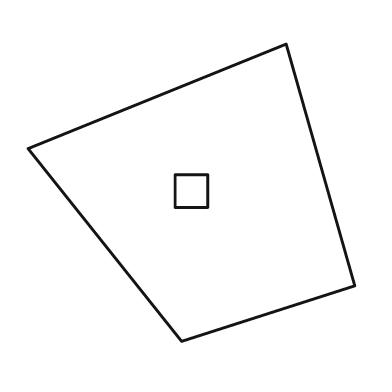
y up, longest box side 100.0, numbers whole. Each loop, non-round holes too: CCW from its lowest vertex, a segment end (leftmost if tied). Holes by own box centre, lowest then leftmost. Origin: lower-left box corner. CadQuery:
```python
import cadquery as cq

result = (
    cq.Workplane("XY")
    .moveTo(47.0, 0.0)
    .lineTo(100.0, 17.0)
    .lineTo(79.0, 91.0)
    .lineTo(0.0, 59.0)
    .close()
    .moveTo(45.0, 41.0)
    .lineTo(55.0, 41.0)
    .lineTo(55.0, 51.0)
    .lineTo(45.0, 51.0)
    .close()
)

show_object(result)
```